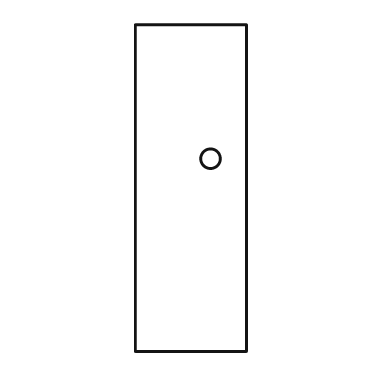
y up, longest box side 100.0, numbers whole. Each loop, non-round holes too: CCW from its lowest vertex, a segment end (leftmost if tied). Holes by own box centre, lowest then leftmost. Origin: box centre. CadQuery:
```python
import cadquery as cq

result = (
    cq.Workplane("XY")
    .moveTo(-17.0, -50.0)
    .lineTo(17.0, -50.0)
    .lineTo(17.0, 50.0)
    .lineTo(-17.0, 50.0)
    .close()
    .moveTo(6.0, 9.0)
    .circle(3.0)
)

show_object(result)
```